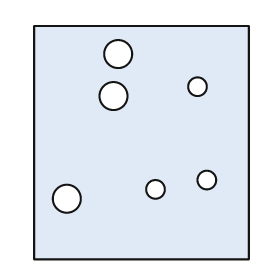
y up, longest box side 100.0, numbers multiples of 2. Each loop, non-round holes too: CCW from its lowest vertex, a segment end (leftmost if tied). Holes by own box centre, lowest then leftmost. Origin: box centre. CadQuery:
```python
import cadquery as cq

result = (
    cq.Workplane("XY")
    .moveTo(-46.0, -50.0)
    .lineTo(46.0, -50.0)
    .lineTo(46.0, 50.0)
    .lineTo(-46.0, 50.0)
    .close()
    .moveTo(-32.0, -24.0)
    .circle(6.0)
    .moveTo(6.0, -20.0)
    .circle(4.0)
    .moveTo(28.0, -16.0)
    .circle(4.0)
    .moveTo(-12.0, 20.0)
    .circle(6.0)
    .moveTo(24.0, 24.0)
    .circle(4.0)
    .moveTo(-10.0, 38.0)
    .circle(6.0)
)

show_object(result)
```